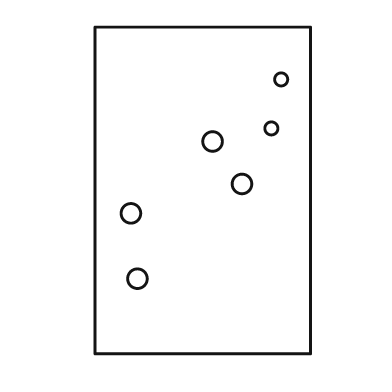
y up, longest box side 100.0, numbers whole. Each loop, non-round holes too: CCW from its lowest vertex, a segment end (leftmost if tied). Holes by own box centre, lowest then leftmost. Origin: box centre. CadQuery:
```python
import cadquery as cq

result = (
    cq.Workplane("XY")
    .moveTo(-33.0, -50.0)
    .lineTo(33.0, -50.0)
    .lineTo(33.0, 50.0)
    .lineTo(-33.0, 50.0)
    .close()
    .moveTo(-20.0, -27.0)
    .circle(3.0)
    .moveTo(-22.0, -7.0)
    .circle(3.0)
    .moveTo(12.0, 2.0)
    .circle(3.0)
    .moveTo(3.0, 15.0)
    .circle(3.0)
    .moveTo(21.0, 19.0)
    .circle(2.0)
    .moveTo(24.0, 34.0)
    .circle(2.0)
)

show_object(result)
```